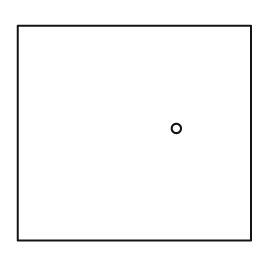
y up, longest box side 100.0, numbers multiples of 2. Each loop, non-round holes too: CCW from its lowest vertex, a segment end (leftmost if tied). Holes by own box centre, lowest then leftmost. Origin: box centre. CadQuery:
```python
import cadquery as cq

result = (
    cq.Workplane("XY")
    .moveTo(-50.0, -46.0)
    .lineTo(50.0, -46.0)
    .lineTo(50.0, 46.0)
    .lineTo(-50.0, 46.0)
    .close()
    .moveTo(18.0, 2.0)
    .circle(2.0)
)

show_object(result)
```